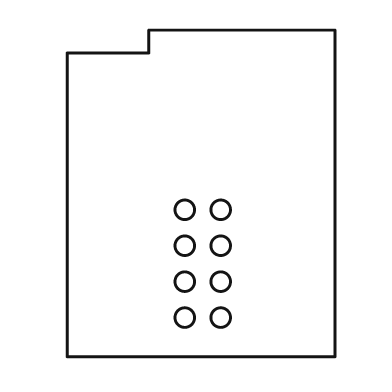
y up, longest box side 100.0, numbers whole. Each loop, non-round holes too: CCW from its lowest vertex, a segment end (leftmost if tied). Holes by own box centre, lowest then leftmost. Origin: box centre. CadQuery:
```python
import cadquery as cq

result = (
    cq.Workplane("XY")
    .moveTo(-41.0, -50.0)
    .lineTo(41.0, -50.0)
    .lineTo(41.0, 50.0)
    .lineTo(-16.0, 50.0)
    .lineTo(-16.0, 43.0)
    .lineTo(-41.0, 43.0)
    .close()
    .moveTo(-5.0, -38.0)
    .circle(3.0)
    .moveTo(6.0, -38.0)
    .circle(3.0)
    .moveTo(-5.0, -27.0)
    .circle(3.0)
    .moveTo(6.0, -27.0)
    .circle(3.0)
    .moveTo(-5.0, -16.0)
    .circle(3.0)
    .moveTo(6.0, -16.0)
    .circle(3.0)
    .moveTo(-5.0, -5.0)
    .circle(3.0)
    .moveTo(6.0, -5.0)
    .circle(3.0)
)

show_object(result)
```